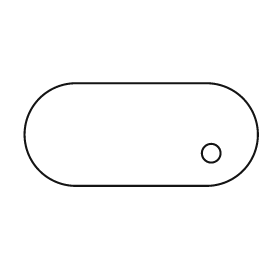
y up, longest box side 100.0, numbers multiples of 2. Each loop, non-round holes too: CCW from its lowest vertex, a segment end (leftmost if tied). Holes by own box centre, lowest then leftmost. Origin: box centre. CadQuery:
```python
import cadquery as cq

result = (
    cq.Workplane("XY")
    .moveTo(-28.0, -22.0)
    .lineTo(28.0, -22.0)
    .threePointArc((50.0, 0.0), (28.0, 22.0))
    .lineTo(-28.0, 22.0)
    .threePointArc((-50.0, 0.0), (-28.0, -22.0))
    .close()
    .moveTo(30.0, -8.0)
    .circle(4.0)
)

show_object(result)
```